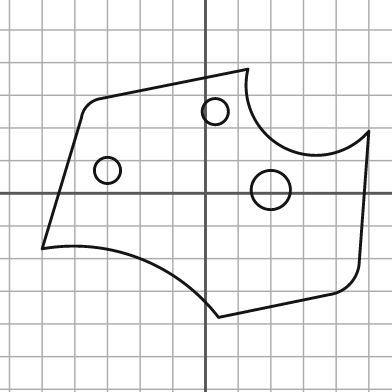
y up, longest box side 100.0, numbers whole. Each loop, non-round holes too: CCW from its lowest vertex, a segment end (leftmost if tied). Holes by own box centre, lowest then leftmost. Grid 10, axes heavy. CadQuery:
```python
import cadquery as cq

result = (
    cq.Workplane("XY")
    .moveTo(4.0, -38.0)
    .lineTo(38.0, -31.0)
    .threePointArc((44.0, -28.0), (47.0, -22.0))
    .lineTo(50.0, 19.0)
    .threePointArc((24.0, 14.0), (13.0, 38.0))
    .lineTo(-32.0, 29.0)
    .threePointArc((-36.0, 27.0), (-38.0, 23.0))
    .lineTo(-50.0, -17.0)
    .threePointArc((-20.0, -20.0), (4.0, -38.0))
    .close()
    .moveTo(20.0, 1.0)
    .circle(6.0)
    .moveTo(-30.0, 7.0)
    .circle(4.0)
    .moveTo(3.0, 25.0)
    .circle(4.0)
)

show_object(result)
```